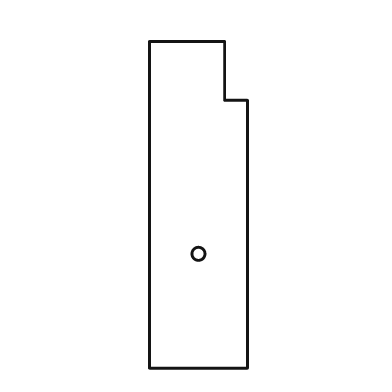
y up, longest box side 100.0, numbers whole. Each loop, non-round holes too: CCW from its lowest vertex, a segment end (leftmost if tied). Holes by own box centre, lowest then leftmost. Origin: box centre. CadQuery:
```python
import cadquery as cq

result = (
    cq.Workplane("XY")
    .moveTo(-15.0, -50.0)
    .lineTo(15.0, -50.0)
    .lineTo(15.0, 32.0)
    .lineTo(8.0, 32.0)
    .lineTo(8.0, 50.0)
    .lineTo(-15.0, 50.0)
    .close()
    .moveTo(0.0, -15.0)
    .circle(2.0)
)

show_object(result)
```